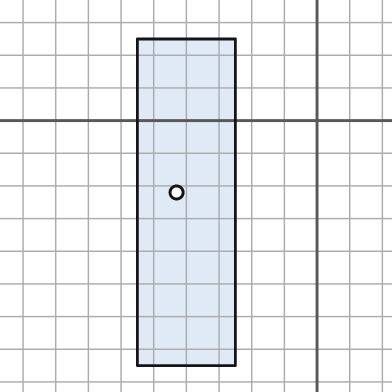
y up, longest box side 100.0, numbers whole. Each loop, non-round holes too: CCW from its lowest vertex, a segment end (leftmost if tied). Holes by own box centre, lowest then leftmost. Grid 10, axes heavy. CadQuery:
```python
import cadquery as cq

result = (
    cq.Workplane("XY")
    .moveTo(-55.0, -75.0)
    .lineTo(-25.0, -75.0)
    .lineTo(-25.0, 25.0)
    .lineTo(-55.0, 25.0)
    .close()
    .moveTo(-43.0, -22.0)
    .circle(2.0)
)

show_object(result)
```